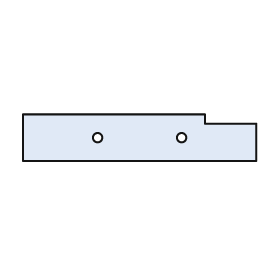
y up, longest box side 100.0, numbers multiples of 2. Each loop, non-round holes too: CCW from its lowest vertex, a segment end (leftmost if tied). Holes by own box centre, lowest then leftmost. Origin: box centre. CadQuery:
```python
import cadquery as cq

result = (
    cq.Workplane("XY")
    .moveTo(-50.0, -10.0)
    .lineTo(50.0, -10.0)
    .lineTo(50.0, 6.0)
    .lineTo(28.0, 6.0)
    .lineTo(28.0, 10.0)
    .lineTo(-50.0, 10.0)
    .close()
    .moveTo(-18.0, 0.0)
    .circle(2.0)
    .moveTo(18.0, 0.0)
    .circle(2.0)
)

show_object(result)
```